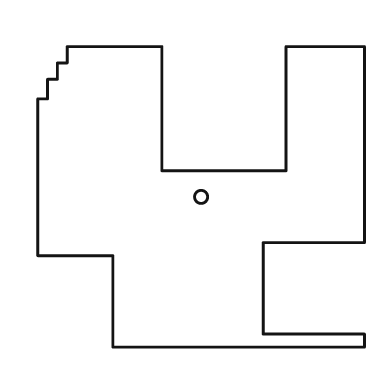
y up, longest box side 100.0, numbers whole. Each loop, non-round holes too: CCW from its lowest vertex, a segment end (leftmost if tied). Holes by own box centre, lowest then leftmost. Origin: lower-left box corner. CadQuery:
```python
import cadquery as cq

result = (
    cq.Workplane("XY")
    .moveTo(23.0, 0.0)
    .lineTo(100.0, 0.0)
    .lineTo(100.0, 4.0)
    .lineTo(69.0, 4.0)
    .lineTo(69.0, 32.0)
    .lineTo(100.0, 32.0)
    .lineTo(100.0, 92.0)
    .lineTo(76.0, 92.0)
    .lineTo(76.0, 54.0)
    .lineTo(38.0, 54.0)
    .lineTo(38.0, 92.0)
    .lineTo(9.0, 92.0)
    .lineTo(9.0, 87.0)
    .lineTo(6.0, 87.0)
    .lineTo(6.0, 82.0)
    .lineTo(3.0, 82.0)
    .lineTo(3.0, 76.0)
    .lineTo(0.0, 76.0)
    .lineTo(0.0, 28.0)
    .lineTo(23.0, 28.0)
    .close()
    .moveTo(50.0, 46.0)
    .circle(2.0)
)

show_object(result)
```